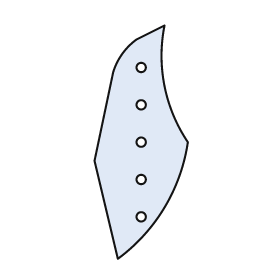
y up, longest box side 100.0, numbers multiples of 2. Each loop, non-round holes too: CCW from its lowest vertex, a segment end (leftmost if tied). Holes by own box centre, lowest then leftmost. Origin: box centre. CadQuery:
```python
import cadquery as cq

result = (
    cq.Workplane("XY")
    .moveTo(-10.0, -50.0)
    .threePointArc((10.0, -28.0), (20.0, 0.0))
    .threePointArc((10.0, 24.0), (10.0, 50.0))
    .lineTo(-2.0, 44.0)
    .threePointArc((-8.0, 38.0), (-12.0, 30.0))
    .lineTo(-20.0, -8.0)
    .close()
    .moveTo(0.0, -32.0)
    .circle(2.0)
    .moveTo(0.0, -16.0)
    .circle(2.0)
    .moveTo(0.0, 0.0)
    .circle(2.0)
    .moveTo(0.0, 16.0)
    .circle(2.0)
    .moveTo(0.0, 32.0)
    .circle(2.0)
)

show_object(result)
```